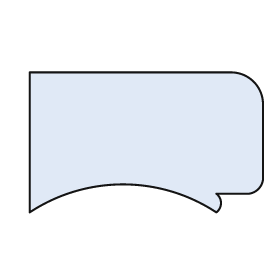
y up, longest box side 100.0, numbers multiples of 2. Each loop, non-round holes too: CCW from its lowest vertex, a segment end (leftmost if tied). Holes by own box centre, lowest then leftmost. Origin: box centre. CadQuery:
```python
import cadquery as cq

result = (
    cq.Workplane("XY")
    .moveTo(-50.0, -30.0)
    .threePointArc((-10.0, -18.0), (30.0, -30.0))
    .threePointArc((32.0, -26.0), (30.0, -22.0))
    .lineTo(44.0, -22.0)
    .threePointArc((48.0, -20.0), (50.0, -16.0))
    .lineTo(50.0, 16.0)
    .threePointArc((46.0, 26.0), (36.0, 30.0))
    .lineTo(-50.0, 30.0)
    .close()
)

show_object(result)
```